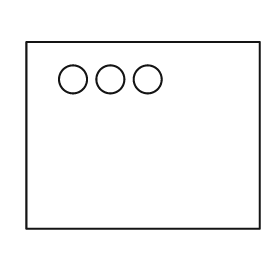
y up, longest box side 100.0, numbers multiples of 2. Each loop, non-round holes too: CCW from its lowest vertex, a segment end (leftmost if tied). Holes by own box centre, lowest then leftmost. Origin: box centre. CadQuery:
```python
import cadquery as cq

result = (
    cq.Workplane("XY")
    .moveTo(-50.0, -40.0)
    .lineTo(50.0, -40.0)
    .lineTo(50.0, 40.0)
    .lineTo(-50.0, 40.0)
    .close()
    .moveTo(-30.0, 24.0)
    .circle(6.0)
    .moveTo(-14.0, 24.0)
    .circle(6.0)
    .moveTo(2.0, 24.0)
    .circle(6.0)
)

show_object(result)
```